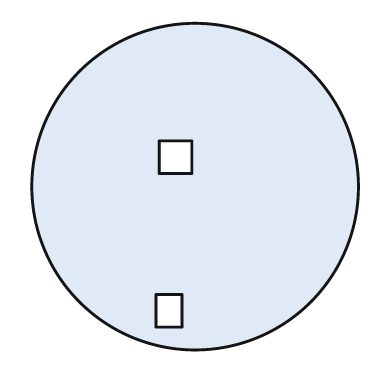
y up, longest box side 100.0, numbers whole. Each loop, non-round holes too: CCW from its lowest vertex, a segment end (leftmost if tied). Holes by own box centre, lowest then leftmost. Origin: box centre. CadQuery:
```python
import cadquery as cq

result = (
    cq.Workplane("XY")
    .moveTo(0.0, 0.0)
    .circle(50.0)
    .moveTo(-12.0, -43.0)
    .lineTo(-4.0, -43.0)
    .lineTo(-4.0, -33.0)
    .lineTo(-12.0, -33.0)
    .close()
    .moveTo(-11.0, 4.0)
    .lineTo(-1.0, 4.0)
    .lineTo(-1.0, 14.0)
    .lineTo(-11.0, 14.0)
    .close()
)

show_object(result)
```